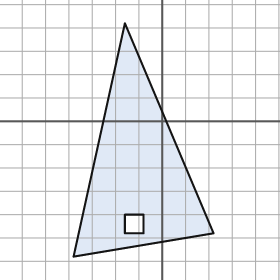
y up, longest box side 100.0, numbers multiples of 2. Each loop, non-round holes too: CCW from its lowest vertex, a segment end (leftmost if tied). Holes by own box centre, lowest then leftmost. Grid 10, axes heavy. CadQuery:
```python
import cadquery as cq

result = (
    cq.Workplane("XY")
    .moveTo(-38.0, -58.0)
    .lineTo(22.0, -48.0)
    .lineTo(-16.0, 42.0)
    .close()
    .moveTo(-16.0, -48.0)
    .lineTo(-8.0, -48.0)
    .lineTo(-8.0, -40.0)
    .lineTo(-16.0, -40.0)
    .close()
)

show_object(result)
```